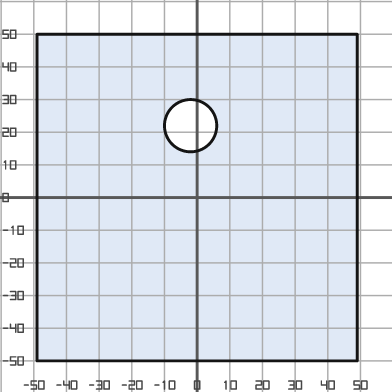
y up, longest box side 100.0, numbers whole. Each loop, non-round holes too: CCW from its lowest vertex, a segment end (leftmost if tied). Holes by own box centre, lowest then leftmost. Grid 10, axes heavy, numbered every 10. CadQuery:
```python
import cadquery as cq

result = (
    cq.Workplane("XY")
    .moveTo(-49.0, -50.0)
    .lineTo(49.0, -50.0)
    .lineTo(49.0, 50.0)
    .lineTo(-49.0, 50.0)
    .close()
    .moveTo(-2.0, 22.0)
    .circle(8.0)
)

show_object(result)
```